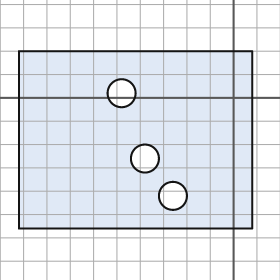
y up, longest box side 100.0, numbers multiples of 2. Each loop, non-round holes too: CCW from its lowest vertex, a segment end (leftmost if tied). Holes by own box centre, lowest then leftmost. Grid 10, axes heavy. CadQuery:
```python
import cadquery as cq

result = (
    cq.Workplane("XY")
    .moveTo(-92.0, -56.0)
    .lineTo(8.0, -56.0)
    .lineTo(8.0, 20.0)
    .lineTo(-92.0, 20.0)
    .close()
    .moveTo(-26.0, -42.0)
    .circle(6.0)
    .moveTo(-38.0, -26.0)
    .circle(6.0)
    .moveTo(-48.0, 2.0)
    .circle(6.0)
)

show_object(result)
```